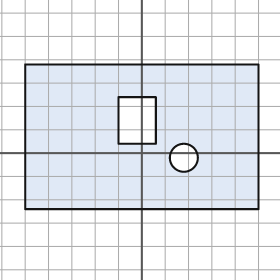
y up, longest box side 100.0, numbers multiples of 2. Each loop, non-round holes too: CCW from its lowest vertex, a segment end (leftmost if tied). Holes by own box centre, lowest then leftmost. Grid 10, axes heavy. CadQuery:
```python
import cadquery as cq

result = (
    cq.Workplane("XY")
    .moveTo(-50.0, -24.0)
    .lineTo(50.0, -24.0)
    .lineTo(50.0, 38.0)
    .lineTo(-50.0, 38.0)
    .close()
    .moveTo(18.0, -2.0)
    .circle(6.0)
    .moveTo(-10.0, 4.0)
    .lineTo(6.0, 4.0)
    .lineTo(6.0, 24.0)
    .lineTo(-10.0, 24.0)
    .close()
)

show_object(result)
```